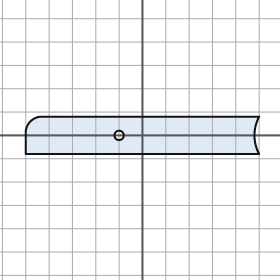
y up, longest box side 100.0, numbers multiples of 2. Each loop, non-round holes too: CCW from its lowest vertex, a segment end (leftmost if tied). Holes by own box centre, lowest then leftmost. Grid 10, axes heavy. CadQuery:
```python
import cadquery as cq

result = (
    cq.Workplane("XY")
    .moveTo(-50.0, -8.0)
    .lineTo(50.0, -8.0)
    .threePointArc((48.0, 0.0), (50.0, 8.0))
    .lineTo(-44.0, 8.0)
    .threePointArc((-48.0, 6.0), (-50.0, 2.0))
    .close()
    .moveTo(-10.0, 0.0)
    .circle(2.0)
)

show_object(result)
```